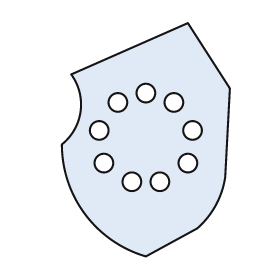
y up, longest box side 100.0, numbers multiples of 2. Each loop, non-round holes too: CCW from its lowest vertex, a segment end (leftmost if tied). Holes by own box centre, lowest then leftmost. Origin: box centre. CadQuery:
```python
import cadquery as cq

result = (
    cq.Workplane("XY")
    .moveTo(0.0, -50.0)
    .lineTo(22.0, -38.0)
    .threePointArc((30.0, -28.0), (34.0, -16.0))
    .lineTo(36.0, 22.0)
    .lineTo(18.0, 50.0)
    .lineTo(-32.0, 28.0)
    .threePointArc((-28.0, 12.0), (-36.0, -2.0))
    .threePointArc((-26.0, -32.0), (0.0, -50.0))
    .close()
    .moveTo(-6.0, -18.0)
    .circle(4.0)
    .moveTo(6.0, -18.0)
    .circle(4.0)
    .moveTo(-18.0, -10.0)
    .circle(4.0)
    .moveTo(18.0, -10.0)
    .circle(4.0)
    .moveTo(-20.0, 4.0)
    .circle(4.0)
    .moveTo(20.0, 4.0)
    .circle(4.0)
    .moveTo(-12.0, 16.0)
    .circle(4.0)
    .moveTo(12.0, 16.0)
    .circle(4.0)
    .moveTo(0.0, 20.0)
    .circle(4.0)
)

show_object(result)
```